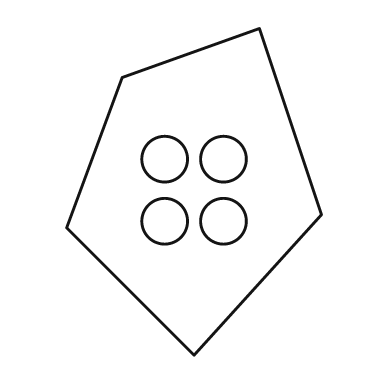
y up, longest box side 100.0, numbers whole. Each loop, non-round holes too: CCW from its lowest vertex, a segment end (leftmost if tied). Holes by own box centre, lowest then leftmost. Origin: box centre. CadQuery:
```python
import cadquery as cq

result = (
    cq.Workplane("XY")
    .moveTo(0.0, -50.0)
    .lineTo(39.0, -7.0)
    .lineTo(20.0, 50.0)
    .lineTo(-22.0, 35.0)
    .lineTo(-39.0, -11.0)
    .close()
    .moveTo(-9.0, -9.0)
    .circle(7.0)
    .moveTo(9.0, -9.0)
    .circle(7.0)
    .moveTo(-9.0, 10.0)
    .circle(7.0)
    .moveTo(9.0, 10.0)
    .circle(7.0)
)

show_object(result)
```